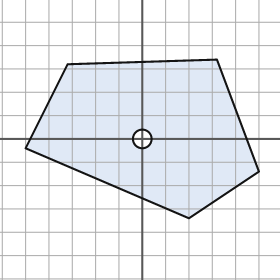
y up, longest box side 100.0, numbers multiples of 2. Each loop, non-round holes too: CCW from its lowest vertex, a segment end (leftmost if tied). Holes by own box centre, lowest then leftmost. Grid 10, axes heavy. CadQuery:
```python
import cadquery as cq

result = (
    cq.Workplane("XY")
    .moveTo(20.0, -34.0)
    .lineTo(50.0, -14.0)
    .lineTo(32.0, 34.0)
    .lineTo(-32.0, 32.0)
    .lineTo(-50.0, -4.0)
    .close()
    .moveTo(0.0, 0.0)
    .circle(4.0)
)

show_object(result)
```